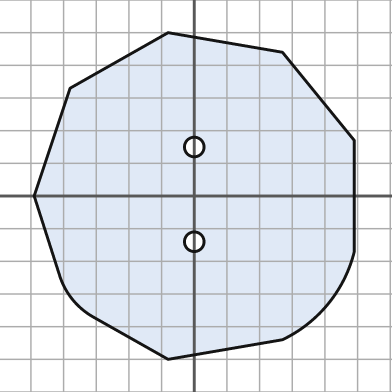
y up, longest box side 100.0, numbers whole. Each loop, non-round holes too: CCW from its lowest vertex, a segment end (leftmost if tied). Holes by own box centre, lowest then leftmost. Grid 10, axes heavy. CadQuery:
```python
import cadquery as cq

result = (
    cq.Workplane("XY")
    .moveTo(-8.0, -50.0)
    .lineTo(27.0, -44.0)
    .threePointArc((41.0, -33.0), (49.0, -17.0))
    .lineTo(49.0, 17.0)
    .lineTo(27.0, 44.0)
    .lineTo(-8.0, 50.0)
    .lineTo(-38.0, 33.0)
    .lineTo(-49.0, 0.0)
    .lineTo(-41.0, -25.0)
    .threePointArc((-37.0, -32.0), (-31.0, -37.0))
    .close()
    .moveTo(0.0, -14.0)
    .circle(3.0)
    .moveTo(0.0, 15.0)
    .circle(3.0)
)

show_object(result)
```